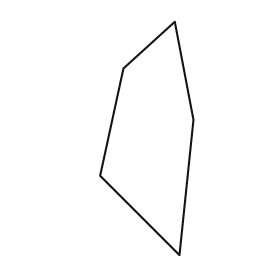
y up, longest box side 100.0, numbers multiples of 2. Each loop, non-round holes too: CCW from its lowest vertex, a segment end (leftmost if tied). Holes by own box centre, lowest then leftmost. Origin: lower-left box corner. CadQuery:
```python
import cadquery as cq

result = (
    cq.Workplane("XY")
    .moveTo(34.0, 0.0)
    .lineTo(40.0, 58.0)
    .lineTo(32.0, 100.0)
    .lineTo(10.0, 80.0)
    .lineTo(0.0, 34.0)
    .close()
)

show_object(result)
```